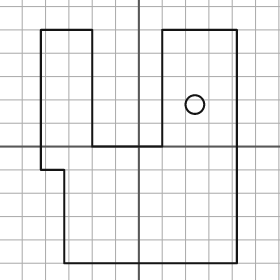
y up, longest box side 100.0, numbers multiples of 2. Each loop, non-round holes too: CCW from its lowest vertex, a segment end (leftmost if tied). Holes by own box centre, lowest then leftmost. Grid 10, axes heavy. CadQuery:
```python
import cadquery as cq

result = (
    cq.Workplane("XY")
    .moveTo(-32.0, -50.0)
    .lineTo(42.0, -50.0)
    .lineTo(42.0, 50.0)
    .lineTo(10.0, 50.0)
    .lineTo(10.0, 0.0)
    .lineTo(-20.0, 0.0)
    .lineTo(-20.0, 50.0)
    .lineTo(-42.0, 50.0)
    .lineTo(-42.0, -10.0)
    .lineTo(-32.0, -10.0)
    .close()
    .moveTo(24.0, 18.0)
    .circle(4.0)
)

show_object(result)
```